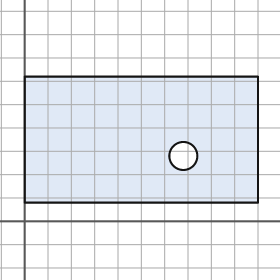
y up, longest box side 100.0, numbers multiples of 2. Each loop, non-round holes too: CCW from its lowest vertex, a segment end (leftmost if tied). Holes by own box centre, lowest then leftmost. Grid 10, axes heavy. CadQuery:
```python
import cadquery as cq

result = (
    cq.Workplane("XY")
    .moveTo(0.0, 8.0)
    .lineTo(100.0, 8.0)
    .lineTo(100.0, 62.0)
    .lineTo(0.0, 62.0)
    .close()
    .moveTo(68.0, 28.0)
    .circle(6.0)
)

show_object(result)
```